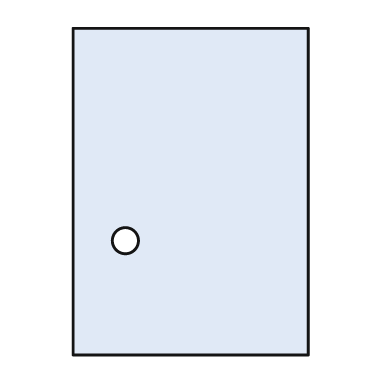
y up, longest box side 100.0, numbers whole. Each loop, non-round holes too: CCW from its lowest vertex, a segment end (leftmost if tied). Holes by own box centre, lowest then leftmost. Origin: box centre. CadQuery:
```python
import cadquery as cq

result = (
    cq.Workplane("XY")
    .moveTo(-36.0, -50.0)
    .lineTo(36.0, -50.0)
    .lineTo(36.0, 50.0)
    .lineTo(-36.0, 50.0)
    .close()
    .moveTo(-20.0, -15.0)
    .circle(4.0)
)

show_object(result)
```